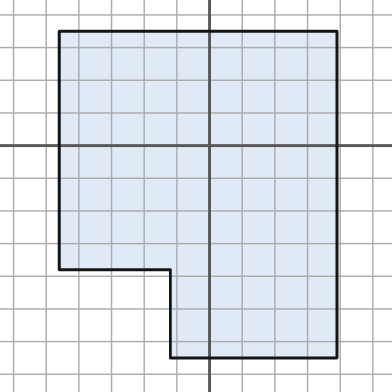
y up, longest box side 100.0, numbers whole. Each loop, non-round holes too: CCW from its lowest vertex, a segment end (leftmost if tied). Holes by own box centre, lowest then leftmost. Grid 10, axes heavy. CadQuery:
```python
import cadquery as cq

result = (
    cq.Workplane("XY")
    .moveTo(-12.0, -65.0)
    .lineTo(39.0, -65.0)
    .lineTo(39.0, 35.0)
    .lineTo(-46.0, 35.0)
    .lineTo(-46.0, -38.0)
    .lineTo(-12.0, -38.0)
    .close()
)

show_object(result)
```